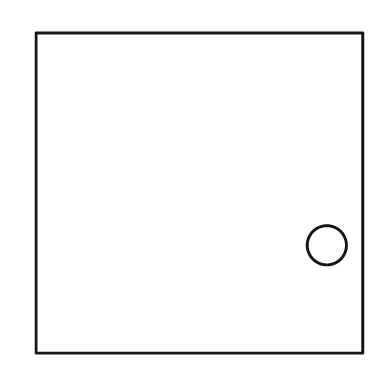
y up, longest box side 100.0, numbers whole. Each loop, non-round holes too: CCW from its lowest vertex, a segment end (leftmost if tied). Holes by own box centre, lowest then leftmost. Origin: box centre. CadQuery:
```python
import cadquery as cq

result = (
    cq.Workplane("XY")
    .moveTo(-50.0, -49.0)
    .lineTo(50.0, -49.0)
    .lineTo(50.0, 49.0)
    .lineTo(-50.0, 49.0)
    .close()
    .moveTo(39.0, -16.0)
    .circle(6.0)
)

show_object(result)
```